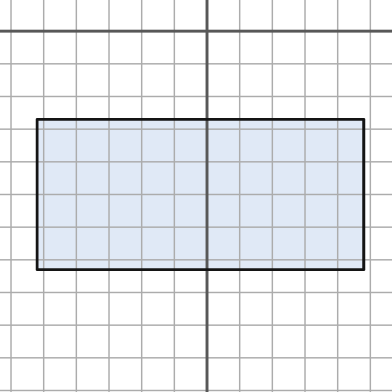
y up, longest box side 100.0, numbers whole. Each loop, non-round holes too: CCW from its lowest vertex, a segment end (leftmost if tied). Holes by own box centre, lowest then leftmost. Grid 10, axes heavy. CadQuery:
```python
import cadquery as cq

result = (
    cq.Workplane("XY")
    .moveTo(-52.0, -73.0)
    .lineTo(48.0, -73.0)
    .lineTo(48.0, -27.0)
    .lineTo(-52.0, -27.0)
    .close()
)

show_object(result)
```